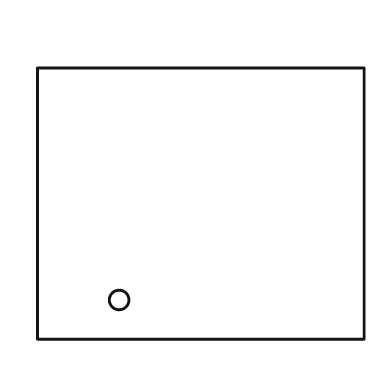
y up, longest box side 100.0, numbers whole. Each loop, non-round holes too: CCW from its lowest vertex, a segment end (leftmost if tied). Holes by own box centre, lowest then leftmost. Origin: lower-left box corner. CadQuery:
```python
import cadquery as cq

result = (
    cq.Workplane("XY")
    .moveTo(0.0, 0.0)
    .lineTo(100.0, 0.0)
    .lineTo(100.0, 83.0)
    .lineTo(0.0, 83.0)
    .close()
    .moveTo(25.0, 12.0)
    .circle(3.0)
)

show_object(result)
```